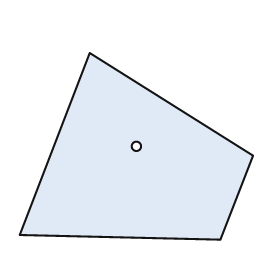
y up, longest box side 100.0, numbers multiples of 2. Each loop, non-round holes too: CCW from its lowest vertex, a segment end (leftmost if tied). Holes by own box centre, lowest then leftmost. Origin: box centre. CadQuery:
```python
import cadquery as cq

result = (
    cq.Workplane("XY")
    .moveTo(36.0, -40.0)
    .lineTo(50.0, -4.0)
    .lineTo(-20.0, 40.0)
    .lineTo(-50.0, -38.0)
    .close()
    .moveTo(0.0, 0.0)
    .circle(2.0)
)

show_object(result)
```